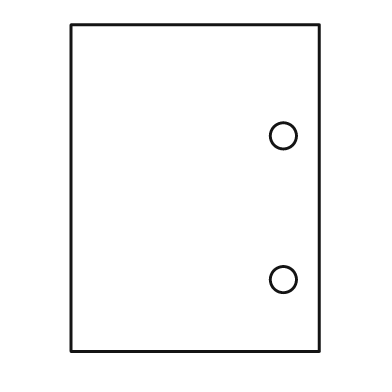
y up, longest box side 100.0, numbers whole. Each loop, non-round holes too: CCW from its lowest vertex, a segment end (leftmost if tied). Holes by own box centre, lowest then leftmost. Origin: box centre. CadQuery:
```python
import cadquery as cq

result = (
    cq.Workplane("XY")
    .moveTo(-38.0, -50.0)
    .lineTo(38.0, -50.0)
    .lineTo(38.0, 50.0)
    .lineTo(-38.0, 50.0)
    .close()
    .moveTo(27.0, -28.0)
    .circle(4.0)
    .moveTo(27.0, 16.0)
    .circle(4.0)
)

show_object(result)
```